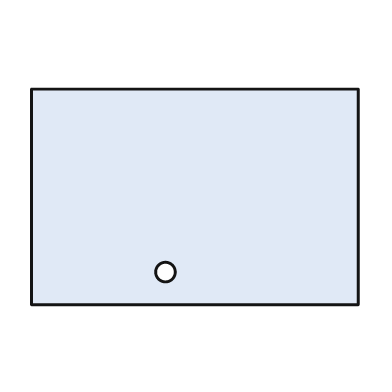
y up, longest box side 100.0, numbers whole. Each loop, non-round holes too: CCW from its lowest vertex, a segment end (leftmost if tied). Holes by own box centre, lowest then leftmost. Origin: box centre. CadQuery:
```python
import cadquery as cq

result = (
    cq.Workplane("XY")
    .moveTo(-50.0, -33.0)
    .lineTo(50.0, -33.0)
    .lineTo(50.0, 33.0)
    .lineTo(-50.0, 33.0)
    .close()
    .moveTo(-9.0, -23.0)
    .circle(3.0)
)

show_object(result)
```